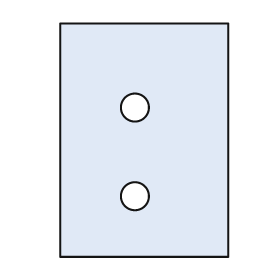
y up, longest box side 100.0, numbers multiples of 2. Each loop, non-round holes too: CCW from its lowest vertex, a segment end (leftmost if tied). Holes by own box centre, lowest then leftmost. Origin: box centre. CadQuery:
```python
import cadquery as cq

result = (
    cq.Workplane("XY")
    .moveTo(-36.0, -50.0)
    .lineTo(36.0, -50.0)
    .lineTo(36.0, 50.0)
    .lineTo(-36.0, 50.0)
    .close()
    .moveTo(-4.0, -24.0)
    .circle(6.0)
    .moveTo(-4.0, 14.0)
    .circle(6.0)
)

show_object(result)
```